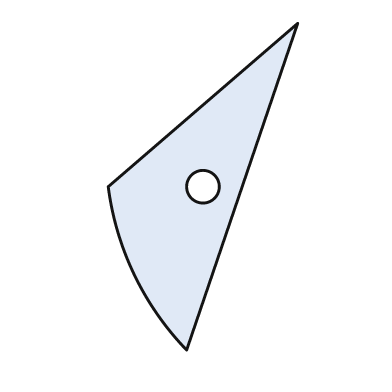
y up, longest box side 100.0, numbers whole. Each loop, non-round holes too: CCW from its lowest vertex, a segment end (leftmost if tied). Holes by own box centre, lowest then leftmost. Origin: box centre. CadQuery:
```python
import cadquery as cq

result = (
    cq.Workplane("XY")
    .moveTo(-5.0, -50.0)
    .lineTo(29.0, 50.0)
    .lineTo(-29.0, 0.0)
    .threePointArc((-21.0, -27.0), (-5.0, -50.0))
    .close()
    .moveTo(0.0, 0.0)
    .circle(5.0)
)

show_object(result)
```